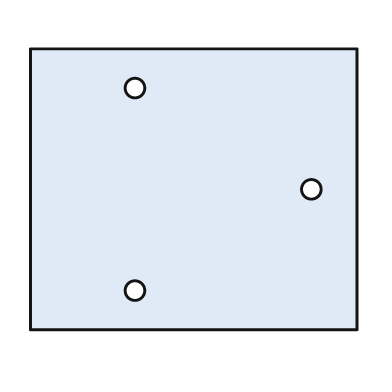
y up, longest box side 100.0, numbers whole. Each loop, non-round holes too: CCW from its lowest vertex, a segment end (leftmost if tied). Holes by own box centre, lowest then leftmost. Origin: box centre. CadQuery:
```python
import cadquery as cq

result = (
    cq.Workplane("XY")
    .moveTo(-50.0, -43.0)
    .lineTo(50.0, -43.0)
    .lineTo(50.0, 43.0)
    .lineTo(-50.0, 43.0)
    .close()
    .moveTo(-18.0, -31.0)
    .circle(3.0)
    .moveTo(36.0, 0.0)
    .circle(3.0)
    .moveTo(-18.0, 31.0)
    .circle(3.0)
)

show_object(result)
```